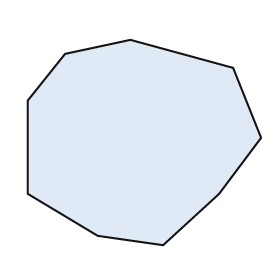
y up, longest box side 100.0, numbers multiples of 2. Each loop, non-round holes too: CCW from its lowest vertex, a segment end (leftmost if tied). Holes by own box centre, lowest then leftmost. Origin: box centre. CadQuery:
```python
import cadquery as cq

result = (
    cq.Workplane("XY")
    .moveTo(8.0, -44.0)
    .lineTo(32.0, -22.0)
    .lineTo(50.0, 2.0)
    .lineTo(38.0, 32.0)
    .lineTo(-6.0, 44.0)
    .lineTo(-34.0, 38.0)
    .lineTo(-50.0, 18.0)
    .lineTo(-50.0, -22.0)
    .lineTo(-20.0, -40.0)
    .close()
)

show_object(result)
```